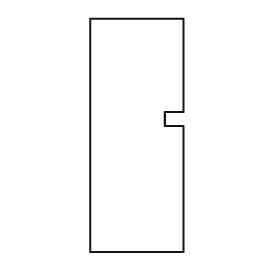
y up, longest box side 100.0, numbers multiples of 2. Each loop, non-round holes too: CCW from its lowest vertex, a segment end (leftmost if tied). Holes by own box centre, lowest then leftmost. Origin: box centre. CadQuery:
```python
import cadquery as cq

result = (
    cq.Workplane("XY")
    .moveTo(-20.0, -50.0)
    .lineTo(20.0, -50.0)
    .lineTo(20.0, 4.0)
    .lineTo(12.0, 4.0)
    .lineTo(12.0, 10.0)
    .lineTo(20.0, 10.0)
    .lineTo(20.0, 50.0)
    .lineTo(-20.0, 50.0)
    .close()
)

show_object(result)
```